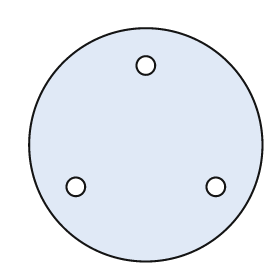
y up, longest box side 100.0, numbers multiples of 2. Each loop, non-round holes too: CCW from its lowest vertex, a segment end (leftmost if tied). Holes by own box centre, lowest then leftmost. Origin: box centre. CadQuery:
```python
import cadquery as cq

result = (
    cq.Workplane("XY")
    .moveTo(0.0, 0.0)
    .circle(50.0)
    .moveTo(-30.0, -18.0)
    .circle(4.0)
    .moveTo(30.0, -18.0)
    .circle(4.0)
    .moveTo(0.0, 34.0)
    .circle(4.0)
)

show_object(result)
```